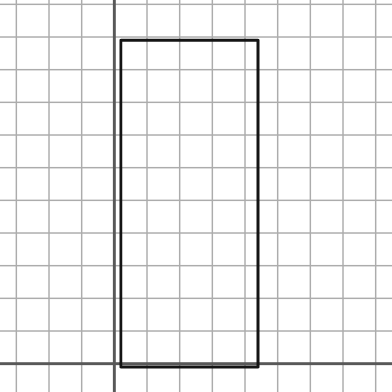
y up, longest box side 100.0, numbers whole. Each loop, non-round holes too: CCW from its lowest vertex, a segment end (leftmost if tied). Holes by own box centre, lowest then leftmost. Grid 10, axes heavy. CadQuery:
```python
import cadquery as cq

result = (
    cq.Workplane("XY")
    .moveTo(2.0, -1.0)
    .lineTo(44.0, -1.0)
    .lineTo(44.0, 99.0)
    .lineTo(2.0, 99.0)
    .close()
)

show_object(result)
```